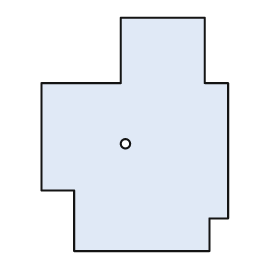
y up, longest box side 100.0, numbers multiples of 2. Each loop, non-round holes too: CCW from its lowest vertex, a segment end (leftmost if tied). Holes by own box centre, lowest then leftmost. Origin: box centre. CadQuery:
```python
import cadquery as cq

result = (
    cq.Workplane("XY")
    .moveTo(-26.0, -50.0)
    .lineTo(32.0, -50.0)
    .lineTo(32.0, -36.0)
    .lineTo(40.0, -36.0)
    .lineTo(40.0, 22.0)
    .lineTo(30.0, 22.0)
    .lineTo(30.0, 50.0)
    .lineTo(-6.0, 50.0)
    .lineTo(-6.0, 22.0)
    .lineTo(-40.0, 22.0)
    .lineTo(-40.0, -24.0)
    .lineTo(-26.0, -24.0)
    .close()
    .moveTo(-4.0, -4.0)
    .circle(2.0)
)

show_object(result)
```